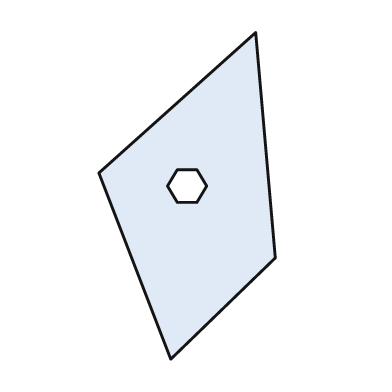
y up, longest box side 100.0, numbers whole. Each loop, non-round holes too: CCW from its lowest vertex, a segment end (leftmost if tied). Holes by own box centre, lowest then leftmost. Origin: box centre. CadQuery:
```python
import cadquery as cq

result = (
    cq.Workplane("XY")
    .moveTo(-5.0, -50.0)
    .lineTo(27.0, -19.0)
    .lineTo(21.0, 50.0)
    .lineTo(-27.0, 7.0)
    .close()
    .moveTo(-3.0, -2.0)
    .lineTo(3.0, -2.0)
    .lineTo(6.0, 3.0)
    .lineTo(3.0, 8.0)
    .lineTo(-3.0, 8.0)
    .lineTo(-6.0, 3.0)
    .close()
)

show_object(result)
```